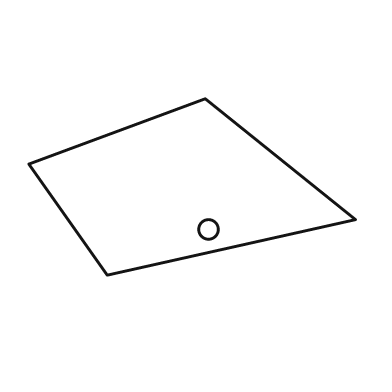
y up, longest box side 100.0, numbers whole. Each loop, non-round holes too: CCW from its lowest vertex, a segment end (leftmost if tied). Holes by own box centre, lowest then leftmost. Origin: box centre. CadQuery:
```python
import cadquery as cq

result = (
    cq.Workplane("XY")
    .moveTo(-26.0, -27.0)
    .lineTo(50.0, -10.0)
    .lineTo(4.0, 27.0)
    .lineTo(-50.0, 7.0)
    .close()
    .moveTo(5.0, -13.0)
    .circle(3.0)
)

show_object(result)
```